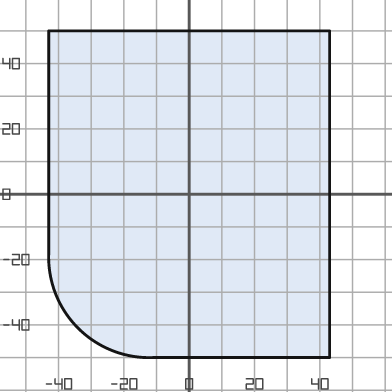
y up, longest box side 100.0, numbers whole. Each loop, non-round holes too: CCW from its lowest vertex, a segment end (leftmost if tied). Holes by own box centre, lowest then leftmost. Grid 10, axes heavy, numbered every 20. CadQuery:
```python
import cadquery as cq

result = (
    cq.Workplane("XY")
    .moveTo(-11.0, -50.0)
    .lineTo(43.0, -50.0)
    .lineTo(43.0, 50.0)
    .lineTo(-43.0, 50.0)
    .lineTo(-43.0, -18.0)
    .threePointArc((-34.0, -41.0), (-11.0, -50.0))
    .close()
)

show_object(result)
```